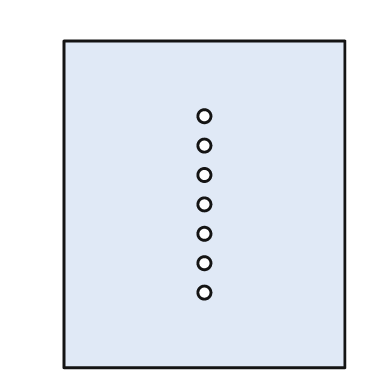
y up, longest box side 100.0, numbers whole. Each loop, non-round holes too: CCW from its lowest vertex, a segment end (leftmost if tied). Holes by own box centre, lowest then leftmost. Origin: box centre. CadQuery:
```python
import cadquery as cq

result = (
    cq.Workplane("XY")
    .moveTo(-43.0, -50.0)
    .lineTo(43.0, -50.0)
    .lineTo(43.0, 50.0)
    .lineTo(-43.0, 50.0)
    .close()
    .moveTo(0.0, -27.0)
    .circle(2.0)
    .moveTo(0.0, -18.0)
    .circle(2.0)
    .moveTo(0.0, -9.0)
    .circle(2.0)
    .moveTo(0.0, 0.0)
    .circle(2.0)
    .moveTo(0.0, 9.0)
    .circle(2.0)
    .moveTo(0.0, 18.0)
    .circle(2.0)
    .moveTo(0.0, 27.0)
    .circle(2.0)
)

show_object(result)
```